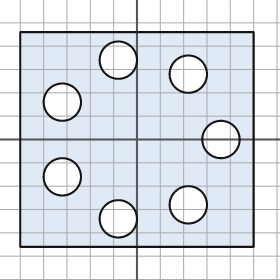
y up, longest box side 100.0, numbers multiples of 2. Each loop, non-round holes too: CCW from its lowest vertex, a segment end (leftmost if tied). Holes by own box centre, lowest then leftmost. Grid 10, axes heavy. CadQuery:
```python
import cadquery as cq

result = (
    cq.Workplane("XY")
    .moveTo(-50.0, -46.0)
    .lineTo(50.0, -46.0)
    .lineTo(50.0, 46.0)
    .lineTo(-50.0, 46.0)
    .close()
    .moveTo(-8.0, -34.0)
    .circle(8.0)
    .moveTo(22.0, -28.0)
    .circle(8.0)
    .moveTo(-32.0, -16.0)
    .circle(8.0)
    .moveTo(36.0, 0.0)
    .circle(8.0)
    .moveTo(-32.0, 16.0)
    .circle(8.0)
    .moveTo(22.0, 28.0)
    .circle(8.0)
    .moveTo(-8.0, 34.0)
    .circle(8.0)
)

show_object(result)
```